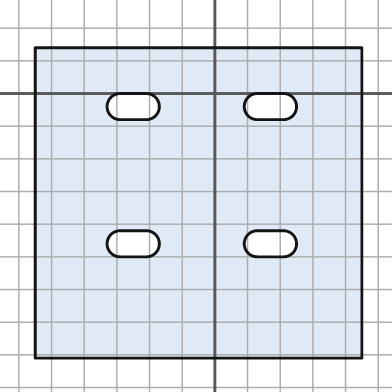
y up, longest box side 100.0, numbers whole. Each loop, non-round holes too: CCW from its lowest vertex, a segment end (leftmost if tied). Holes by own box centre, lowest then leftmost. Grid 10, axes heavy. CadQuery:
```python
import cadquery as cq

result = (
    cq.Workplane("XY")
    .moveTo(-55.0, -81.0)
    .lineTo(45.0, -81.0)
    .lineTo(45.0, 14.0)
    .lineTo(-55.0, 14.0)
    .close()
    .moveTo(-29.0, -50.0)
    .lineTo(-21.0, -50.0)
    .threePointArc((-17.0, -46.0), (-21.0, -42.0))
    .lineTo(-29.0, -42.0)
    .threePointArc((-33.0, -46.0), (-29.0, -50.0))
    .close()
    .moveTo(13.0, -50.0)
    .lineTo(21.0, -50.0)
    .threePointArc((25.0, -46.0), (21.0, -42.0))
    .lineTo(13.0, -42.0)
    .threePointArc((9.0, -46.0), (13.0, -50.0))
    .close()
    .moveTo(-29.0, -8.0)
    .lineTo(-21.0, -8.0)
    .threePointArc((-17.0, -4.0), (-21.0, 0.0))
    .lineTo(-29.0, 0.0)
    .threePointArc((-33.0, -4.0), (-29.0, -8.0))
    .close()
    .moveTo(13.0, -8.0)
    .lineTo(21.0, -8.0)
    .threePointArc((25.0, -4.0), (21.0, 0.0))
    .lineTo(13.0, 0.0)
    .threePointArc((9.0, -4.0), (13.0, -8.0))
    .close()
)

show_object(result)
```